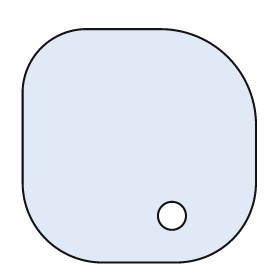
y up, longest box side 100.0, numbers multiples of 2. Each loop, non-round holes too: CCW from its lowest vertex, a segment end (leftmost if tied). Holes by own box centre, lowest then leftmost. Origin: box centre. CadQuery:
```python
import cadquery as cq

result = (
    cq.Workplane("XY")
    .moveTo(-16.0, -50.0)
    .lineTo(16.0, -50.0)
    .threePointArc((40.0, -40.0), (50.0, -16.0))
    .lineTo(50.0, 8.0)
    .threePointArc((38.0, 38.0), (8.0, 50.0))
    .lineTo(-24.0, 50.0)
    .threePointArc((-42.0, 42.0), (-50.0, 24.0))
    .lineTo(-50.0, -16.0)
    .threePointArc((-40.0, -40.0), (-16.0, -50.0))
    .close()
    .moveTo(14.0, -30.0)
    .circle(6.0)
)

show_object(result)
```